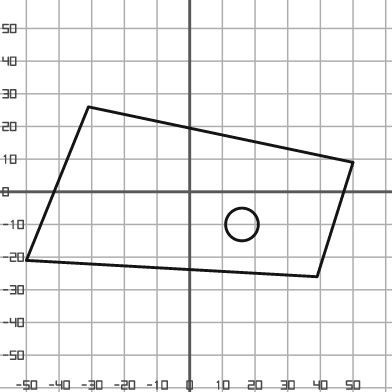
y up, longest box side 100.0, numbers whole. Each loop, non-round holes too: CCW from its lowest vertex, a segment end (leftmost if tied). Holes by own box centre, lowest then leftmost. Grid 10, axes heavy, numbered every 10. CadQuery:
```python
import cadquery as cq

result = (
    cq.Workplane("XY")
    .moveTo(39.0, -26.0)
    .lineTo(50.0, 9.0)
    .lineTo(-31.0, 26.0)
    .lineTo(-50.0, -21.0)
    .close()
    .moveTo(16.0, -10.0)
    .circle(5.0)
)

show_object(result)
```